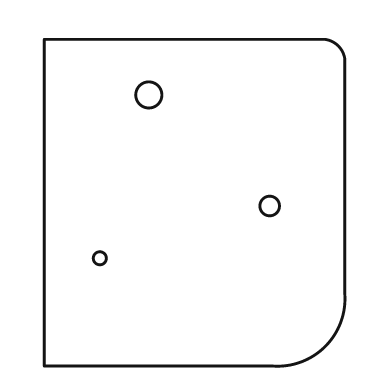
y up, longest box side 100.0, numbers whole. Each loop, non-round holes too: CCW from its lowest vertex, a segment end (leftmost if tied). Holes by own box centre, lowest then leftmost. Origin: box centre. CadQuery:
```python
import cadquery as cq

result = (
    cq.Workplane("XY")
    .moveTo(-46.0, -50.0)
    .lineTo(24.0, -50.0)
    .threePointArc((40.0, -44.0), (46.0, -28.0))
    .lineTo(46.0, 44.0)
    .threePointArc((44.0, 48.0), (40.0, 50.0))
    .lineTo(-46.0, 50.0)
    .close()
    .moveTo(-29.0, -17.0)
    .circle(2.0)
    .moveTo(23.0, -1.0)
    .circle(3.0)
    .moveTo(-14.0, 33.0)
    .circle(4.0)
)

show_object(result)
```